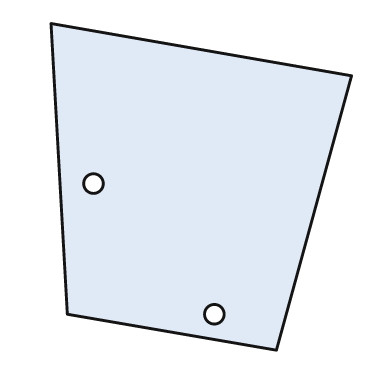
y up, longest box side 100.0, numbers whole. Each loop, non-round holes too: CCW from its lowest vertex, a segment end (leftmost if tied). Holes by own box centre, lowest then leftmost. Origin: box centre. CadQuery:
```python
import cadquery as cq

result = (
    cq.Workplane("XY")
    .moveTo(23.0, -50.0)
    .lineTo(46.0, 34.0)
    .lineTo(-46.0, 50.0)
    .lineTo(-41.0, -39.0)
    .close()
    .moveTo(4.0, -39.0)
    .circle(3.0)
    .moveTo(-33.0, 1.0)
    .circle(3.0)
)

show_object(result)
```